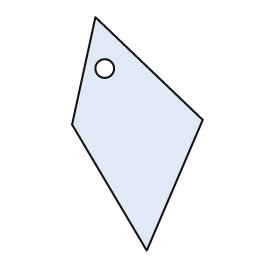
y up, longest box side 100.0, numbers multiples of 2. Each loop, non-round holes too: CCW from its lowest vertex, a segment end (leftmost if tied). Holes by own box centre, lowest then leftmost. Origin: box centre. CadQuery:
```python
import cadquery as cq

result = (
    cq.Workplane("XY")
    .moveTo(4.0, -50.0)
    .lineTo(28.0, 6.0)
    .lineTo(-18.0, 50.0)
    .lineTo(-28.0, 4.0)
    .close()
    .moveTo(-14.0, 28.0)
    .circle(4.0)
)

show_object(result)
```